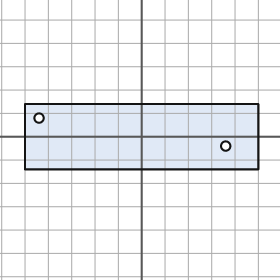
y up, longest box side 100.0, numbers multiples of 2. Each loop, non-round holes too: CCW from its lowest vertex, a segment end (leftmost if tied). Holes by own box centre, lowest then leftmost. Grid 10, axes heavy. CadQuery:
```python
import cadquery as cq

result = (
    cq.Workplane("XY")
    .moveTo(-50.0, -14.0)
    .lineTo(50.0, -14.0)
    .lineTo(50.0, 14.0)
    .lineTo(-50.0, 14.0)
    .close()
    .moveTo(36.0, -4.0)
    .circle(2.0)
    .moveTo(-44.0, 8.0)
    .circle(2.0)
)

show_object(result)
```